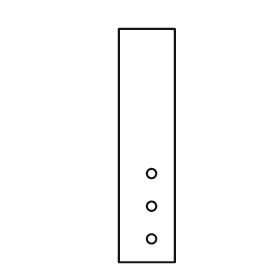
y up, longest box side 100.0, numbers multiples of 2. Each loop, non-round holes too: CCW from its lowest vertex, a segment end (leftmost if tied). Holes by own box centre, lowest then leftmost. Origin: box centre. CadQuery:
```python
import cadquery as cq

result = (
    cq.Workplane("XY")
    .moveTo(-12.0, -50.0)
    .lineTo(12.0, -50.0)
    .lineTo(12.0, 50.0)
    .lineTo(-12.0, 50.0)
    .close()
    .moveTo(2.0, -40.0)
    .circle(2.0)
    .moveTo(2.0, -26.0)
    .circle(2.0)
    .moveTo(2.0, -12.0)
    .circle(2.0)
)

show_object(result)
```